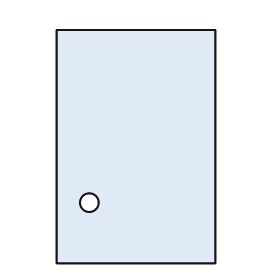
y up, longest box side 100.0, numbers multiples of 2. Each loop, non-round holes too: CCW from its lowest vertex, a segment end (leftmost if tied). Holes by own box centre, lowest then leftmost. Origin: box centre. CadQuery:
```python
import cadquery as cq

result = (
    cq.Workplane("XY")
    .moveTo(-34.0, -50.0)
    .lineTo(34.0, -50.0)
    .lineTo(34.0, 50.0)
    .lineTo(-34.0, 50.0)
    .close()
    .moveTo(-20.0, -24.0)
    .circle(4.0)
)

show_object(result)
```